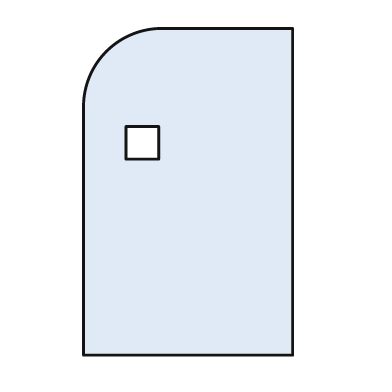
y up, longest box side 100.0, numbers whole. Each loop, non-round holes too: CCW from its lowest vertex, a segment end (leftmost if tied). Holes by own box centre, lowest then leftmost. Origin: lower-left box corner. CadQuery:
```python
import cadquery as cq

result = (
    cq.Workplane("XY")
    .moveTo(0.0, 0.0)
    .lineTo(64.0, 0.0)
    .lineTo(64.0, 100.0)
    .lineTo(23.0, 100.0)
    .threePointArc((7.0, 93.0), (0.0, 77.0))
    .close()
    .moveTo(13.0, 60.0)
    .lineTo(23.0, 60.0)
    .lineTo(23.0, 70.0)
    .lineTo(13.0, 70.0)
    .close()
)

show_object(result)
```